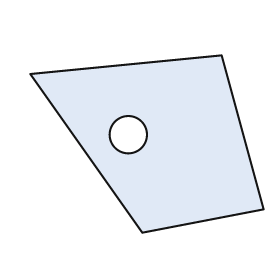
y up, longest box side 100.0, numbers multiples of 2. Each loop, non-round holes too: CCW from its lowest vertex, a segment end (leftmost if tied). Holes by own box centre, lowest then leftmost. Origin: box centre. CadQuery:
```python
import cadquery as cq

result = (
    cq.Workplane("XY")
    .moveTo(-2.0, -38.0)
    .lineTo(50.0, -28.0)
    .lineTo(32.0, 38.0)
    .lineTo(-50.0, 30.0)
    .close()
    .moveTo(-8.0, 4.0)
    .circle(8.0)
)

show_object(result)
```